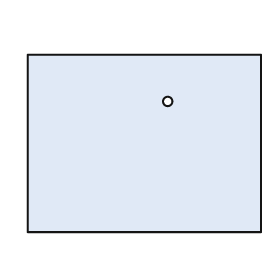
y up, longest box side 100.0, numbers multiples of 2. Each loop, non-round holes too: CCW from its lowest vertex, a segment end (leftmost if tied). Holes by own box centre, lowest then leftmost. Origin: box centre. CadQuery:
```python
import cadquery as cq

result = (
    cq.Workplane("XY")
    .moveTo(-50.0, -38.0)
    .lineTo(50.0, -38.0)
    .lineTo(50.0, 38.0)
    .lineTo(-50.0, 38.0)
    .close()
    .moveTo(10.0, 18.0)
    .circle(2.0)
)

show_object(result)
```